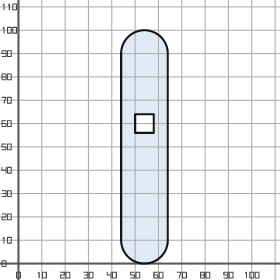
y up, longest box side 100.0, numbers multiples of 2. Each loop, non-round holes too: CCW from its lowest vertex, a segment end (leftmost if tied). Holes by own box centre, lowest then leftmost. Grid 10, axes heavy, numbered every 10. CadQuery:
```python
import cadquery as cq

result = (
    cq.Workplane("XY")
    .moveTo(44.0, 10.0)
    .threePointArc((54.0, 0.0), (64.0, 10.0))
    .lineTo(64.0, 90.0)
    .threePointArc((54.0, 100.0), (44.0, 90.0))
    .close()
    .moveTo(50.0, 56.0)
    .lineTo(58.0, 56.0)
    .lineTo(58.0, 64.0)
    .lineTo(50.0, 64.0)
    .close()
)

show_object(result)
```